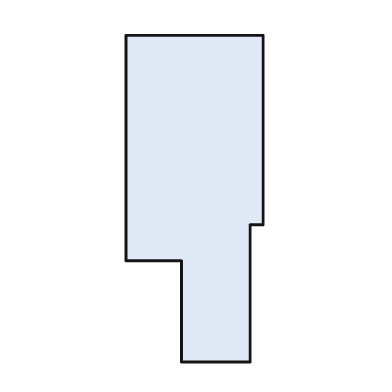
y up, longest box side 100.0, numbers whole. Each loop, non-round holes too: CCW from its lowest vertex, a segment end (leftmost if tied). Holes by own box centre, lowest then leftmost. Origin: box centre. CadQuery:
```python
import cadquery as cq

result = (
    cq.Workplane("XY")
    .moveTo(-4.0, -50.0)
    .lineTo(17.0, -50.0)
    .lineTo(17.0, -8.0)
    .lineTo(21.0, -8.0)
    .lineTo(21.0, 50.0)
    .lineTo(-21.0, 50.0)
    .lineTo(-21.0, -19.0)
    .lineTo(-4.0, -19.0)
    .close()
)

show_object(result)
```